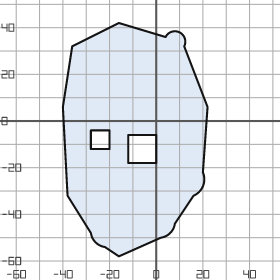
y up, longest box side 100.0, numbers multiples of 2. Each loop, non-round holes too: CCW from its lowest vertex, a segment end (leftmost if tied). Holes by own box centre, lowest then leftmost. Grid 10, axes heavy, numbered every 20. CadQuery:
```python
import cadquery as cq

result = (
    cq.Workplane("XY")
    .moveTo(-16.0, -58.0)
    .lineTo(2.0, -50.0)
    .threePointArc((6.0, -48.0), (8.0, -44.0))
    .lineTo(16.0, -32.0)
    .threePointArc((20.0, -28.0), (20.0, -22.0))
    .lineTo(22.0, 6.0)
    .lineTo(12.0, 32.0)
    .threePointArc((10.0, 38.0), (4.0, 36.0))
    .lineTo(-16.0, 42.0)
    .lineTo(-36.0, 32.0)
    .lineTo(-40.0, 6.0)
    .lineTo(-38.0, -32.0)
    .lineTo(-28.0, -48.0)
    .threePointArc((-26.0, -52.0), (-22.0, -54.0))
    .close()
    .moveTo(-12.0, -18.0)
    .lineTo(0.0, -18.0)
    .lineTo(0.0, -6.0)
    .lineTo(-12.0, -6.0)
    .close()
    .moveTo(-28.0, -12.0)
    .lineTo(-20.0, -12.0)
    .lineTo(-20.0, -4.0)
    .lineTo(-28.0, -4.0)
    .close()
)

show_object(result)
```